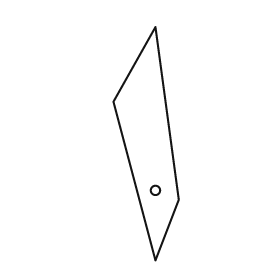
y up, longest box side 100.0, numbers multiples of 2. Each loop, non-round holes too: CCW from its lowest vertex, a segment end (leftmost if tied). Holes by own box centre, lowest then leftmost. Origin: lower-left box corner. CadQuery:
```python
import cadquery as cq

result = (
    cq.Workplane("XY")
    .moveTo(18.0, 0.0)
    .lineTo(28.0, 26.0)
    .lineTo(18.0, 100.0)
    .lineTo(0.0, 68.0)
    .close()
    .moveTo(18.0, 30.0)
    .circle(2.0)
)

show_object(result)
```